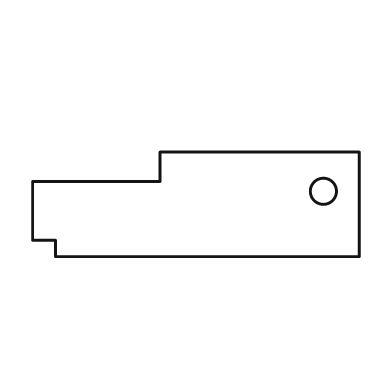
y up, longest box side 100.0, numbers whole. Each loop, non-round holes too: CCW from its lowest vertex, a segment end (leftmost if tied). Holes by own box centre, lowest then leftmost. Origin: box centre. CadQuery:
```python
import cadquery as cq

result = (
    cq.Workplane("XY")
    .moveTo(-43.0, -16.0)
    .lineTo(50.0, -16.0)
    .lineTo(50.0, 16.0)
    .lineTo(-11.0, 16.0)
    .lineTo(-11.0, 7.0)
    .lineTo(-50.0, 7.0)
    .lineTo(-50.0, -11.0)
    .lineTo(-43.0, -11.0)
    .close()
    .moveTo(39.0, 4.0)
    .circle(4.0)
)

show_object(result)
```